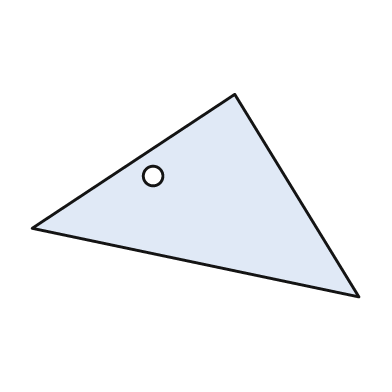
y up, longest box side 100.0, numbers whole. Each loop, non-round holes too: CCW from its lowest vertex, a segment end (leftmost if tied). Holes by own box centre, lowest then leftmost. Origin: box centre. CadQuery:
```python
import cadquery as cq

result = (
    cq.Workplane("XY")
    .moveTo(50.0, -31.0)
    .lineTo(12.0, 31.0)
    .lineTo(-50.0, -10.0)
    .close()
    .moveTo(-13.0, 6.0)
    .circle(3.0)
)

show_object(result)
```